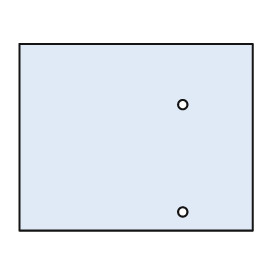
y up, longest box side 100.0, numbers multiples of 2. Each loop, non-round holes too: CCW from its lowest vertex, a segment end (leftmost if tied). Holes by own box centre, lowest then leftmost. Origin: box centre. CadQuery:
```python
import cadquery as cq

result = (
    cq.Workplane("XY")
    .moveTo(-50.0, -40.0)
    .lineTo(50.0, -40.0)
    .lineTo(50.0, 40.0)
    .lineTo(-50.0, 40.0)
    .close()
    .moveTo(20.0, -32.0)
    .circle(2.0)
    .moveTo(20.0, 14.0)
    .circle(2.0)
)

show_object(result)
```